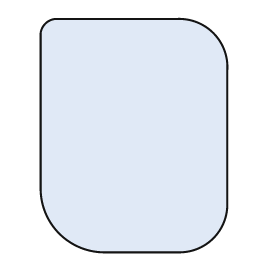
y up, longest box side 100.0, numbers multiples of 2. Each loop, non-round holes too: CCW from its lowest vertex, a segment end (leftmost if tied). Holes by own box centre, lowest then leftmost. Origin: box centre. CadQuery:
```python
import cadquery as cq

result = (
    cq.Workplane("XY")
    .moveTo(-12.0, -50.0)
    .lineTo(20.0, -50.0)
    .threePointArc((34.0, -44.0), (40.0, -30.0))
    .lineTo(40.0, 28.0)
    .threePointArc((34.0, 44.0), (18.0, 50.0))
    .lineTo(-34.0, 50.0)
    .threePointArc((-38.0, 48.0), (-40.0, 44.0))
    .lineTo(-40.0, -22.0)
    .threePointArc((-32.0, -42.0), (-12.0, -50.0))
    .close()
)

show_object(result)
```